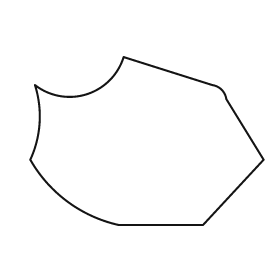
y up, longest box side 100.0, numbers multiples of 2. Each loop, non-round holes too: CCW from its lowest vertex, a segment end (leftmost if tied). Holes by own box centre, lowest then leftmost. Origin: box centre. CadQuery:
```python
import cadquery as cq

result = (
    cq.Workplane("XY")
    .moveTo(-12.0, -36.0)
    .lineTo(24.0, -36.0)
    .lineTo(50.0, -8.0)
    .lineTo(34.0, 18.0)
    .threePointArc((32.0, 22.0), (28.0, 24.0))
    .lineTo(-10.0, 36.0)
    .threePointArc((-26.0, 20.0), (-48.0, 24.0))
    .threePointArc((-46.0, 8.0), (-50.0, -8.0))
    .threePointArc((-34.0, -26.0), (-12.0, -36.0))
    .close()
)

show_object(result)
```